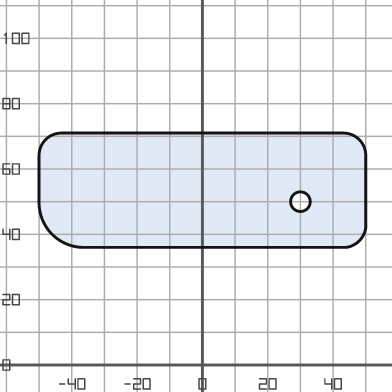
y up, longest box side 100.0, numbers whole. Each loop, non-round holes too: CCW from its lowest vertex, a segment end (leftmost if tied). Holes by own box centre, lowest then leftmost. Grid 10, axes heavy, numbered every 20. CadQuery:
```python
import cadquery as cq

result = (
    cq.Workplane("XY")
    .moveTo(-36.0, 36.0)
    .lineTo(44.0, 36.0)
    .threePointArc((48.0, 38.0), (50.0, 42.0))
    .lineTo(50.0, 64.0)
    .threePointArc((48.0, 69.0), (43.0, 71.0))
    .lineTo(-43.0, 71.0)
    .threePointArc((-48.0, 69.0), (-50.0, 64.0))
    .lineTo(-50.0, 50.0)
    .threePointArc((-46.0, 40.0), (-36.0, 36.0))
    .close()
    .moveTo(30.0, 50.0)
    .circle(3.0)
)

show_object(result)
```